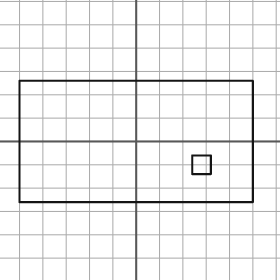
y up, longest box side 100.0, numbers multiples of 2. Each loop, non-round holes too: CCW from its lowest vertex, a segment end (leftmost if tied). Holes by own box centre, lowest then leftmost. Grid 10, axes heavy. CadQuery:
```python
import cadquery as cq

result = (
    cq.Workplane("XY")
    .moveTo(-50.0, -26.0)
    .lineTo(50.0, -26.0)
    .lineTo(50.0, 26.0)
    .lineTo(-50.0, 26.0)
    .close()
    .moveTo(24.0, -14.0)
    .lineTo(32.0, -14.0)
    .lineTo(32.0, -6.0)
    .lineTo(24.0, -6.0)
    .close()
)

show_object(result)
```